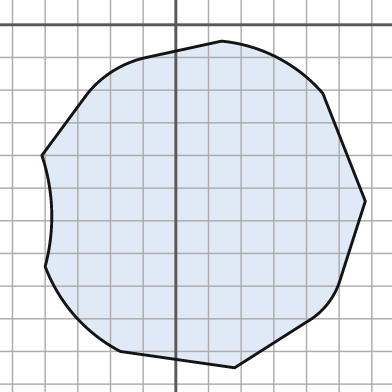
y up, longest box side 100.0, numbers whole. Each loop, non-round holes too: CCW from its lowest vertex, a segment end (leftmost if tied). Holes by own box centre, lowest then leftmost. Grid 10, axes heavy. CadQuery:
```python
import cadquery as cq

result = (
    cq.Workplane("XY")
    .moveTo(18.0, -105.0)
    .lineTo(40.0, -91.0)
    .threePointArc((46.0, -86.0), (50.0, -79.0))
    .lineTo(58.0, -54.0)
    .lineTo(45.0, -21.0)
    .threePointArc((31.0, -10.0), (14.0, -5.0))
    .lineTo(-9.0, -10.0)
    .threePointArc((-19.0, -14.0), (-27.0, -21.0))
    .lineTo(-41.0, -40.0)
    .threePointArc((-38.0, -57.0), (-40.0, -74.0))
    .threePointArc((-31.0, -89.0), (-17.0, -100.0))
    .close()
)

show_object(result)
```